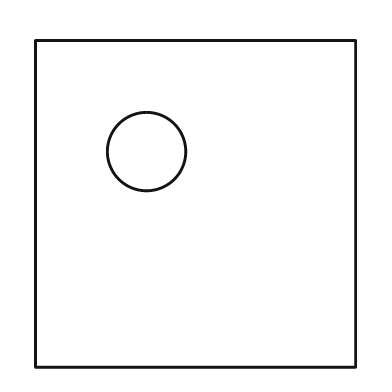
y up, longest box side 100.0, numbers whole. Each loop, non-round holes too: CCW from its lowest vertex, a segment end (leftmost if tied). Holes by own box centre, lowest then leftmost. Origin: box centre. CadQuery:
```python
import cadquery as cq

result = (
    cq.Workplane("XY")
    .moveTo(-49.0, -50.0)
    .lineTo(49.0, -50.0)
    .lineTo(49.0, 50.0)
    .lineTo(-49.0, 50.0)
    .close()
    .moveTo(-15.0, 16.0)
    .circle(12.0)
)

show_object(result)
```